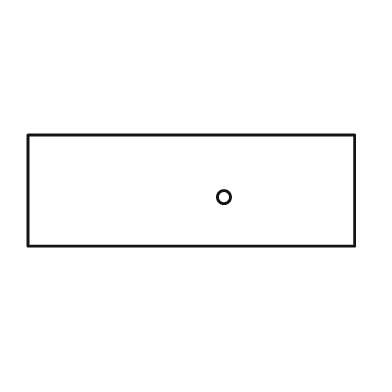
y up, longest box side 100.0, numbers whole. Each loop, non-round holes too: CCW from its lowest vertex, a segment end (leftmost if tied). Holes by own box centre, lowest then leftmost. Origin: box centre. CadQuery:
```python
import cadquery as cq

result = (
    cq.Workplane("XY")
    .moveTo(-50.0, -17.0)
    .lineTo(50.0, -17.0)
    .lineTo(50.0, 17.0)
    .lineTo(-50.0, 17.0)
    .close()
    .moveTo(10.0, -2.0)
    .circle(2.0)
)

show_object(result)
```